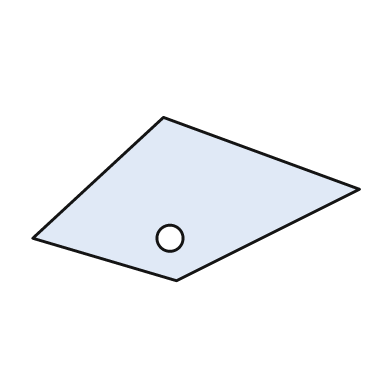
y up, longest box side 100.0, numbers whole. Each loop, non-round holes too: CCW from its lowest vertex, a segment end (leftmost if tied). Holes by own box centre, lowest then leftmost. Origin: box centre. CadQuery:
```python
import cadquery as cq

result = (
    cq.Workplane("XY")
    .moveTo(-6.0, -25.0)
    .lineTo(50.0, 3.0)
    .lineTo(-10.0, 25.0)
    .lineTo(-50.0, -12.0)
    .close()
    .moveTo(-8.0, -12.0)
    .circle(4.0)
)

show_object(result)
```